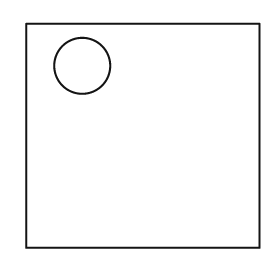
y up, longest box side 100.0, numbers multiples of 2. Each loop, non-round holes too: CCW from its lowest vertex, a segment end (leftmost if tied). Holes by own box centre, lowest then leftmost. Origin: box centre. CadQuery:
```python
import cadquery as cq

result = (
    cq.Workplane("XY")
    .moveTo(-50.0, -48.0)
    .lineTo(50.0, -48.0)
    .lineTo(50.0, 48.0)
    .lineTo(-50.0, 48.0)
    .close()
    .moveTo(-26.0, 30.0)
    .circle(12.0)
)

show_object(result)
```